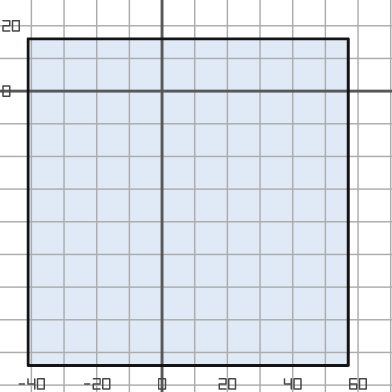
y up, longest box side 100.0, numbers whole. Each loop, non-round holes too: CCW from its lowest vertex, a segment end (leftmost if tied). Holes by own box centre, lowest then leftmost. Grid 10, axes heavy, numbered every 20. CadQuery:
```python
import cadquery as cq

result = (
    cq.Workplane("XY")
    .moveTo(-41.0, -84.0)
    .lineTo(57.0, -84.0)
    .lineTo(57.0, 16.0)
    .lineTo(-41.0, 16.0)
    .close()
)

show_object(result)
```